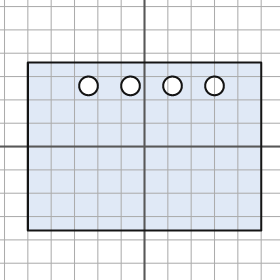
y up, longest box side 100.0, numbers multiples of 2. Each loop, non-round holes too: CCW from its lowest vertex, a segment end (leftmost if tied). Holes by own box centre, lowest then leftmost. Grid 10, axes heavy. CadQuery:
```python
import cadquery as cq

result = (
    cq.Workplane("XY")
    .moveTo(-50.0, -36.0)
    .lineTo(50.0, -36.0)
    .lineTo(50.0, 36.0)
    .lineTo(-50.0, 36.0)
    .close()
    .moveTo(-24.0, 26.0)
    .circle(4.0)
    .moveTo(-6.0, 26.0)
    .circle(4.0)
    .moveTo(12.0, 26.0)
    .circle(4.0)
    .moveTo(30.0, 26.0)
    .circle(4.0)
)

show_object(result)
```